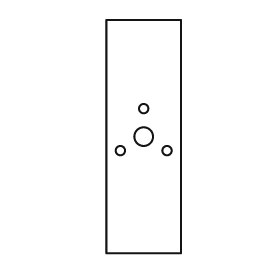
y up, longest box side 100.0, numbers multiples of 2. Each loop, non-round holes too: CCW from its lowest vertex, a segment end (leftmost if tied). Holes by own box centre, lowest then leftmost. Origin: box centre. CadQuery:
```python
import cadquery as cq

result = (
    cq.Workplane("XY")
    .moveTo(-16.0, -50.0)
    .lineTo(16.0, -50.0)
    .lineTo(16.0, 50.0)
    .lineTo(-16.0, 50.0)
    .close()
    .moveTo(-10.0, -6.0)
    .circle(2.0)
    .moveTo(10.0, -6.0)
    .circle(2.0)
    .moveTo(0.0, 0.0)
    .circle(4.0)
    .moveTo(0.0, 12.0)
    .circle(2.0)
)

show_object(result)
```